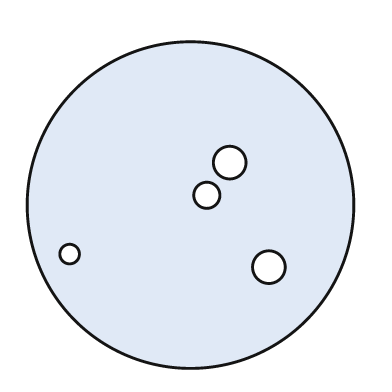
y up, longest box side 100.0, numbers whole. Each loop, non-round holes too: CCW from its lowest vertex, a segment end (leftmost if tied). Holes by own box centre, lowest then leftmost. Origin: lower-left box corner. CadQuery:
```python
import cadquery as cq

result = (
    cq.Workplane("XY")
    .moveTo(50.0, 50.0)
    .circle(50.0)
    .moveTo(74.0, 31.0)
    .circle(5.0)
    .moveTo(13.0, 35.0)
    .circle(3.0)
    .moveTo(55.0, 53.0)
    .circle(4.0)
    .moveTo(62.0, 63.0)
    .circle(5.0)
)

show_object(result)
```